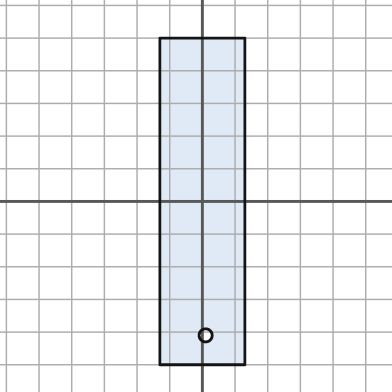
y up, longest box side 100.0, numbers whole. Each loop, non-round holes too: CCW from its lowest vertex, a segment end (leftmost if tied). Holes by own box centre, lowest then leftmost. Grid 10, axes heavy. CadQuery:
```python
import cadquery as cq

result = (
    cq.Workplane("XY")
    .moveTo(-13.0, -50.0)
    .lineTo(13.0, -50.0)
    .lineTo(13.0, 50.0)
    .lineTo(-13.0, 50.0)
    .close()
    .moveTo(1.0, -41.0)
    .circle(2.0)
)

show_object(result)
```